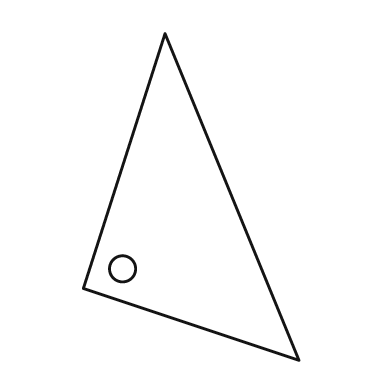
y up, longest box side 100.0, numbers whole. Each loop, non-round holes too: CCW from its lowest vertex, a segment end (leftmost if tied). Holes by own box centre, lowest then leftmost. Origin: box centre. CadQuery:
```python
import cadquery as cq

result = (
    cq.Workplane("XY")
    .moveTo(33.0, -50.0)
    .lineTo(-8.0, 50.0)
    .lineTo(-33.0, -28.0)
    .close()
    .moveTo(-21.0, -22.0)
    .circle(4.0)
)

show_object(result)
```